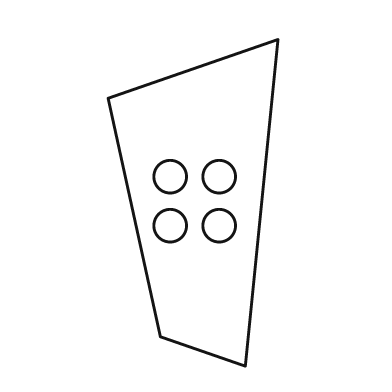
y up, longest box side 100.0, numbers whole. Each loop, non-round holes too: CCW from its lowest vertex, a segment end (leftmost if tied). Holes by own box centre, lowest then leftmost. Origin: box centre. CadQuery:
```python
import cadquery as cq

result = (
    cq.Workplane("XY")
    .moveTo(16.0, -50.0)
    .lineTo(26.0, 50.0)
    .lineTo(-26.0, 32.0)
    .lineTo(-10.0, -41.0)
    .close()
    .moveTo(-7.0, -7.0)
    .circle(5.0)
    .moveTo(8.0, -7.0)
    .circle(5.0)
    .moveTo(-7.0, 8.0)
    .circle(5.0)
    .moveTo(8.0, 8.0)
    .circle(5.0)
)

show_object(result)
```